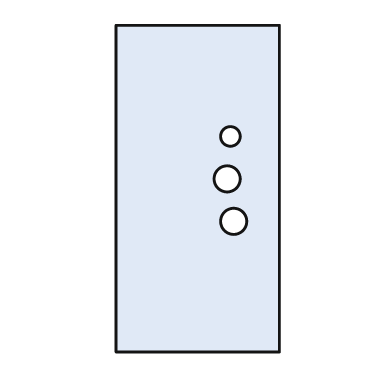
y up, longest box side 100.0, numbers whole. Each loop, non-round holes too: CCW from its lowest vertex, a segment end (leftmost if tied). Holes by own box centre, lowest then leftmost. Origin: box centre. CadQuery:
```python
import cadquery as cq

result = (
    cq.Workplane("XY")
    .moveTo(-25.0, -50.0)
    .lineTo(25.0, -50.0)
    .lineTo(25.0, 50.0)
    .lineTo(-25.0, 50.0)
    .close()
    .moveTo(11.0, -10.0)
    .circle(4.0)
    .moveTo(9.0, 3.0)
    .circle(4.0)
    .moveTo(10.0, 16.0)
    .circle(3.0)
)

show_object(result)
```